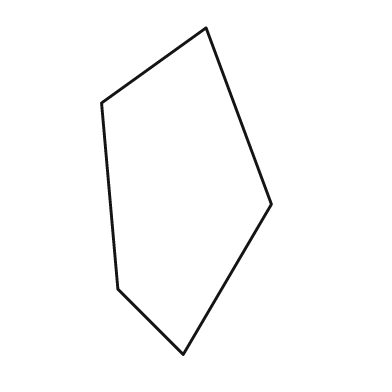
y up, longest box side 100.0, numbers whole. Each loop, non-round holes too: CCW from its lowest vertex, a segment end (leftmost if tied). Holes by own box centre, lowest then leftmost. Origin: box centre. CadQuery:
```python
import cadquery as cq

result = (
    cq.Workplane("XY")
    .moveTo(-1.0, -50.0)
    .lineTo(26.0, -4.0)
    .lineTo(6.0, 50.0)
    .lineTo(-26.0, 27.0)
    .lineTo(-21.0, -30.0)
    .close()
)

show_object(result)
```